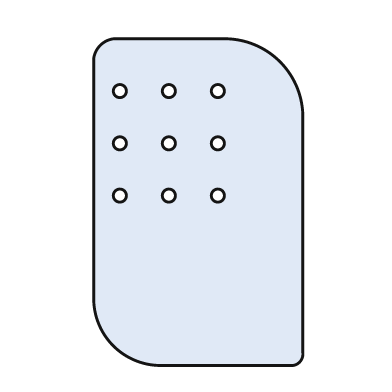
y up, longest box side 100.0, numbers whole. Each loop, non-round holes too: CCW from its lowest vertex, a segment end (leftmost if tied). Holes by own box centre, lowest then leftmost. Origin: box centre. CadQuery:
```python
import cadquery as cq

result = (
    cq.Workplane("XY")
    .moveTo(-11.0, -50.0)
    .lineTo(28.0, -50.0)
    .threePointArc((31.0, -49.0), (32.0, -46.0))
    .lineTo(32.0, 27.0)
    .threePointArc((25.0, 43.0), (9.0, 50.0))
    .lineTo(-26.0, 50.0)
    .threePointArc((-30.0, 48.0), (-32.0, 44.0))
    .lineTo(-32.0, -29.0)
    .threePointArc((-26.0, -44.0), (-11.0, -50.0))
    .close()
    .moveTo(-24.0, 2.0)
    .circle(2.0)
    .moveTo(-9.0, 2.0)
    .circle(2.0)
    .moveTo(6.0, 2.0)
    .circle(2.0)
    .moveTo(-24.0, 18.0)
    .circle(2.0)
    .moveTo(-9.0, 18.0)
    .circle(2.0)
    .moveTo(6.0, 18.0)
    .circle(2.0)
    .moveTo(-24.0, 34.0)
    .circle(2.0)
    .moveTo(-9.0, 34.0)
    .circle(2.0)
    .moveTo(6.0, 34.0)
    .circle(2.0)
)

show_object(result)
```